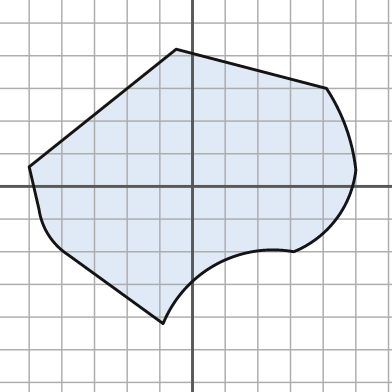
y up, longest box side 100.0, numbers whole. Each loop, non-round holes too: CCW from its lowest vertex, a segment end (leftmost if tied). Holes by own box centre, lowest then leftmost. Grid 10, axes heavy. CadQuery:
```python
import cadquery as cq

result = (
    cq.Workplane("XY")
    .moveTo(-9.0, -42.0)
    .threePointArc((7.0, -24.0), (31.0, -20.0))
    .threePointArc((44.0, -10.0), (50.0, 5.0))
    .threePointArc((47.0, 18.0), (41.0, 30.0))
    .lineTo(-5.0, 42.0)
    .lineTo(-50.0, 6.0)
    .lineTo(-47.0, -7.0)
    .threePointArc((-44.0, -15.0), (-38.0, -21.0))
    .close()
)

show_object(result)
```